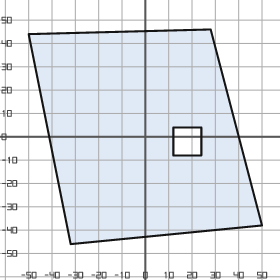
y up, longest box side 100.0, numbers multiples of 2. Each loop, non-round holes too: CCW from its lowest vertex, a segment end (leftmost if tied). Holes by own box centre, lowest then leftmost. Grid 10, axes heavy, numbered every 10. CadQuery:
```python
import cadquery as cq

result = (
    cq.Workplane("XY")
    .moveTo(-32.0, -46.0)
    .lineTo(50.0, -38.0)
    .lineTo(28.0, 46.0)
    .lineTo(-50.0, 44.0)
    .close()
    .moveTo(12.0, -8.0)
    .lineTo(24.0, -8.0)
    .lineTo(24.0, 4.0)
    .lineTo(12.0, 4.0)
    .close()
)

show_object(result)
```